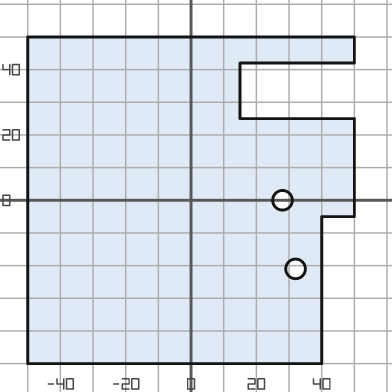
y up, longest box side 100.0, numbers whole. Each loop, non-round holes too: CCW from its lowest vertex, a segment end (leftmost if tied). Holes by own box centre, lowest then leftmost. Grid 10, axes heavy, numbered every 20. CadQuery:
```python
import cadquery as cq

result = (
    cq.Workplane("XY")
    .moveTo(-50.0, -50.0)
    .lineTo(40.0, -50.0)
    .lineTo(40.0, -5.0)
    .lineTo(50.0, -5.0)
    .lineTo(50.0, 25.0)
    .lineTo(15.0, 25.0)
    .lineTo(15.0, 42.0)
    .lineTo(50.0, 42.0)
    .lineTo(50.0, 50.0)
    .lineTo(-50.0, 50.0)
    .close()
    .moveTo(32.0, -21.0)
    .circle(3.0)
    .moveTo(28.0, 0.0)
    .circle(3.0)
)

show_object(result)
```